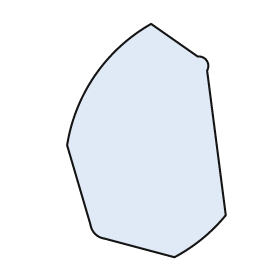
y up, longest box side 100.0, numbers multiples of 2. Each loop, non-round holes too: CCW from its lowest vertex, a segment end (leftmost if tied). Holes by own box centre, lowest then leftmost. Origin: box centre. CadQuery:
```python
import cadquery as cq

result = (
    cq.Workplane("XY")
    .moveTo(12.0, -50.0)
    .threePointArc((24.0, -42.0), (34.0, -32.0))
    .lineTo(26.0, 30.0)
    .threePointArc((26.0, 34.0), (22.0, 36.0))
    .lineTo(2.0, 50.0)
    .threePointArc((-22.0, 28.0), (-34.0, -2.0))
    .lineTo(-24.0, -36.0)
    .threePointArc((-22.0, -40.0), (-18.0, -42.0))
    .close()
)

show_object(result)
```